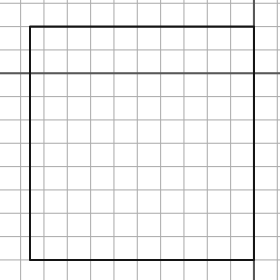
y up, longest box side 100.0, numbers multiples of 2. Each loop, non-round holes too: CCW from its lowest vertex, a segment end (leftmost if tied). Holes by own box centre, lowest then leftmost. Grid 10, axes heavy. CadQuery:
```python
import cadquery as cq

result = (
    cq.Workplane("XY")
    .moveTo(-96.0, -80.0)
    .lineTo(0.0, -80.0)
    .lineTo(0.0, 20.0)
    .lineTo(-96.0, 20.0)
    .close()
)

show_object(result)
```